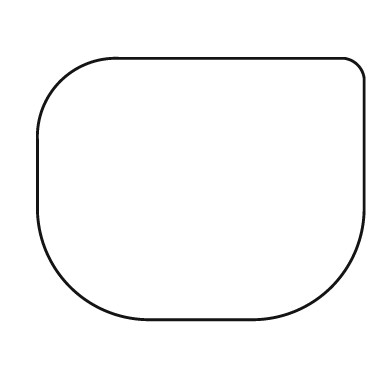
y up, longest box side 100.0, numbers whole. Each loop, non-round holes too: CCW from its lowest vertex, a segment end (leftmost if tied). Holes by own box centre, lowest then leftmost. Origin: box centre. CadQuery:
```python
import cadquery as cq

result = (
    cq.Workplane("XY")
    .moveTo(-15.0, -40.0)
    .lineTo(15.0, -40.0)
    .threePointArc((40.0, -30.0), (50.0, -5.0))
    .lineTo(50.0, 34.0)
    .threePointArc((48.0, 38.0), (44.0, 40.0))
    .lineTo(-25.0, 40.0)
    .threePointArc((-43.0, 33.0), (-50.0, 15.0))
    .lineTo(-50.0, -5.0)
    .threePointArc((-40.0, -30.0), (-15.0, -40.0))
    .close()
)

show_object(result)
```